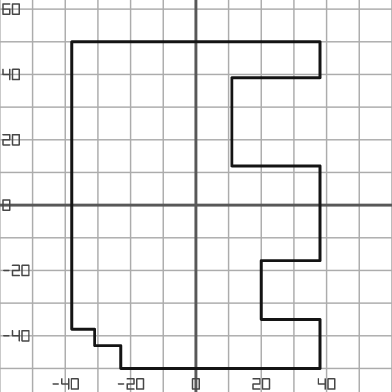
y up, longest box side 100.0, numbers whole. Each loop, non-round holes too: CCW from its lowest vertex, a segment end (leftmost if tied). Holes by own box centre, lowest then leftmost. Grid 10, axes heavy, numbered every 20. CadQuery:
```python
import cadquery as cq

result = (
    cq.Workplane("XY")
    .moveTo(-23.0, -50.0)
    .lineTo(38.0, -50.0)
    .lineTo(38.0, -35.0)
    .lineTo(20.0, -35.0)
    .lineTo(20.0, -17.0)
    .lineTo(38.0, -17.0)
    .lineTo(38.0, 12.0)
    .lineTo(11.0, 12.0)
    .lineTo(11.0, 39.0)
    .lineTo(38.0, 39.0)
    .lineTo(38.0, 50.0)
    .lineTo(-38.0, 50.0)
    .lineTo(-38.0, -38.0)
    .lineTo(-31.0, -38.0)
    .lineTo(-31.0, -43.0)
    .lineTo(-23.0, -43.0)
    .close()
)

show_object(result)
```